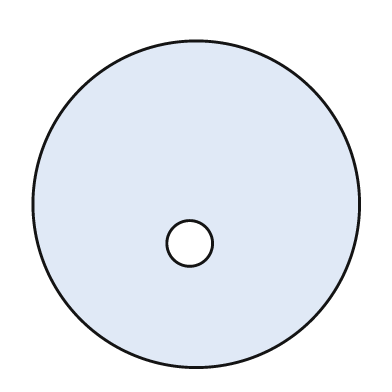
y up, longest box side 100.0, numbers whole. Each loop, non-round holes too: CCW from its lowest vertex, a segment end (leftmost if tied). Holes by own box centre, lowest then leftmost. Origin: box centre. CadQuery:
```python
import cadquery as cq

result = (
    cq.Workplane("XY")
    .moveTo(0.0, 0.0)
    .circle(50.0)
    .moveTo(-2.0, -12.0)
    .circle(7.0)
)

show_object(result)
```